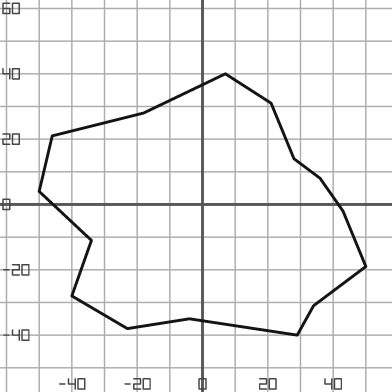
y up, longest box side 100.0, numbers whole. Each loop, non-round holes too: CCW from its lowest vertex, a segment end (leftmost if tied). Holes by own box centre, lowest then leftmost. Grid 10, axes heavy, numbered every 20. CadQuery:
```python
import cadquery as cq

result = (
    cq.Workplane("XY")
    .moveTo(29.0, -40.0)
    .lineTo(34.0, -31.0)
    .lineTo(50.0, -19.0)
    .lineTo(43.0, -2.0)
    .lineTo(36.0, 8.0)
    .lineTo(28.0, 14.0)
    .lineTo(21.0, 31.0)
    .lineTo(7.0, 40.0)
    .lineTo(-18.0, 28.0)
    .lineTo(-46.0, 21.0)
    .lineTo(-50.0, 4.0)
    .lineTo(-34.0, -11.0)
    .lineTo(-40.0, -28.0)
    .lineTo(-23.0, -38.0)
    .lineTo(-4.0, -35.0)
    .close()
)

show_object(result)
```